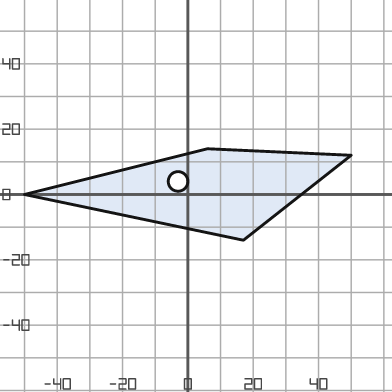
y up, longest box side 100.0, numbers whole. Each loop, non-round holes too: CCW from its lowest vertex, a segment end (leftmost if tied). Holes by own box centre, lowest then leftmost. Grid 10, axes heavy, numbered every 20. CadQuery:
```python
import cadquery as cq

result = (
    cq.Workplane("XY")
    .moveTo(17.0, -14.0)
    .lineTo(50.0, 12.0)
    .lineTo(6.0, 14.0)
    .lineTo(-50.0, 0.0)
    .close()
    .moveTo(-3.0, 4.0)
    .circle(3.0)
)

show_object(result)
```